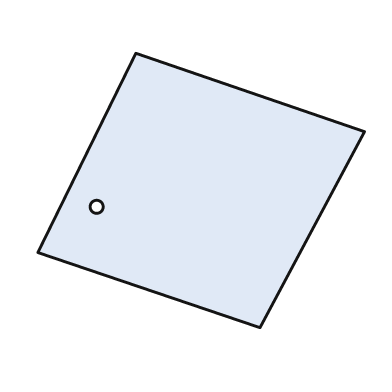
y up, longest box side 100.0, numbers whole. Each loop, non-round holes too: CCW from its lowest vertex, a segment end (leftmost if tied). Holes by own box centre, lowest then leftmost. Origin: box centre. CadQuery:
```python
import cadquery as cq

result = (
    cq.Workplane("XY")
    .moveTo(18.0, -42.0)
    .lineTo(50.0, 18.0)
    .lineTo(-20.0, 42.0)
    .lineTo(-50.0, -19.0)
    .close()
    .moveTo(-32.0, -5.0)
    .circle(2.0)
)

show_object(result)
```